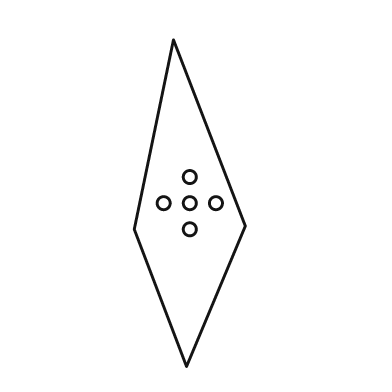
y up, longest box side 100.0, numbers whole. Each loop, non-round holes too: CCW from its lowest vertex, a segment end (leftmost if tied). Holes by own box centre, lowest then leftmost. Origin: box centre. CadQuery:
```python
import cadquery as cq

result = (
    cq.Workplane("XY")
    .moveTo(-1.0, -50.0)
    .lineTo(17.0, -7.0)
    .lineTo(-5.0, 50.0)
    .lineTo(-17.0, -8.0)
    .close()
    .moveTo(0.0, -8.0)
    .circle(2.0)
    .moveTo(-8.0, 0.0)
    .circle(2.0)
    .moveTo(0.0, 0.0)
    .circle(2.0)
    .moveTo(8.0, 0.0)
    .circle(2.0)
    .moveTo(0.0, 8.0)
    .circle(2.0)
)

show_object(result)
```